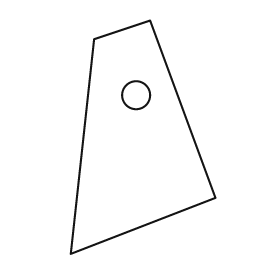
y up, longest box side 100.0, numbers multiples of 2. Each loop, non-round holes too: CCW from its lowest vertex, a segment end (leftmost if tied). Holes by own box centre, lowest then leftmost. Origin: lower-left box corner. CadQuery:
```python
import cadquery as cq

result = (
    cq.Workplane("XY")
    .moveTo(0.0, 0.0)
    .lineTo(62.0, 24.0)
    .lineTo(34.0, 100.0)
    .lineTo(10.0, 92.0)
    .close()
    .moveTo(28.0, 68.0)
    .circle(6.0)
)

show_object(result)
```